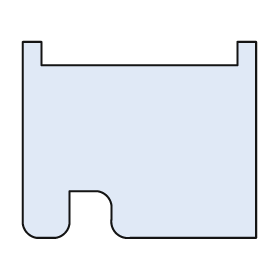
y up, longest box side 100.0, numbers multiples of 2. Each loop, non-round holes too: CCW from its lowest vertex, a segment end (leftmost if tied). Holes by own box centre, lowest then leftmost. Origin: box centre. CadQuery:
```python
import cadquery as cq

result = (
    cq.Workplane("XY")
    .moveTo(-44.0, -42.0)
    .lineTo(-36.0, -42.0)
    .threePointArc((-32.0, -40.0), (-30.0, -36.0))
    .lineTo(-30.0, -22.0)
    .lineTo(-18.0, -22.0)
    .threePointArc((-14.0, -24.0), (-12.0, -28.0))
    .lineTo(-12.0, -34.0)
    .threePointArc((-10.0, -40.0), (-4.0, -42.0))
    .lineTo(50.0, -42.0)
    .lineTo(50.0, 42.0)
    .lineTo(42.0, 42.0)
    .lineTo(42.0, 32.0)
    .lineTo(-42.0, 32.0)
    .lineTo(-42.0, 42.0)
    .lineTo(-50.0, 42.0)
    .lineTo(-50.0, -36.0)
    .threePointArc((-48.0, -40.0), (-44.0, -42.0))
    .close()
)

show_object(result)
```